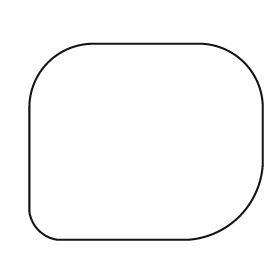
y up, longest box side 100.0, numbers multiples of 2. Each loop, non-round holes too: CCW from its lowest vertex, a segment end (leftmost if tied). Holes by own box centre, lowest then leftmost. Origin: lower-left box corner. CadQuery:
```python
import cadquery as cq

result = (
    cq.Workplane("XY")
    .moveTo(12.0, 0.0)
    .lineTo(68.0, 0.0)
    .threePointArc((90.0, 10.0), (100.0, 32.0))
    .lineTo(100.0, 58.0)
    .threePointArc((92.0, 76.0), (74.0, 84.0))
    .lineTo(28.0, 84.0)
    .threePointArc((8.0, 76.0), (0.0, 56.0))
    .lineTo(0.0, 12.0)
    .threePointArc((4.0, 4.0), (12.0, 0.0))
    .close()
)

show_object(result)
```